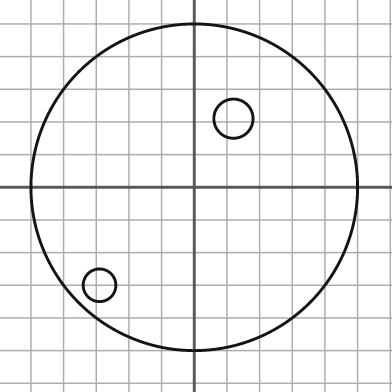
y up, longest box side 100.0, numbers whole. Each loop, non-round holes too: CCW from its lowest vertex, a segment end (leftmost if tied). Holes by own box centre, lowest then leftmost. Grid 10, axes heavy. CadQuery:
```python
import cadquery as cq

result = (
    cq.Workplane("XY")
    .moveTo(0.0, 0.0)
    .circle(50.0)
    .moveTo(-29.0, -30.0)
    .circle(5.0)
    .moveTo(12.0, 21.0)
    .circle(6.0)
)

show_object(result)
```